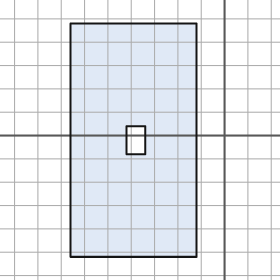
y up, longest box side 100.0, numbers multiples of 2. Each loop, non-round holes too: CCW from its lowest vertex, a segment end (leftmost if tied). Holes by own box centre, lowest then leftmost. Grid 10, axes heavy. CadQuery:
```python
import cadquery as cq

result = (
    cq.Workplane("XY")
    .moveTo(-66.0, -52.0)
    .lineTo(-12.0, -52.0)
    .lineTo(-12.0, 48.0)
    .lineTo(-66.0, 48.0)
    .close()
    .moveTo(-42.0, -8.0)
    .lineTo(-34.0, -8.0)
    .lineTo(-34.0, 4.0)
    .lineTo(-42.0, 4.0)
    .close()
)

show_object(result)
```